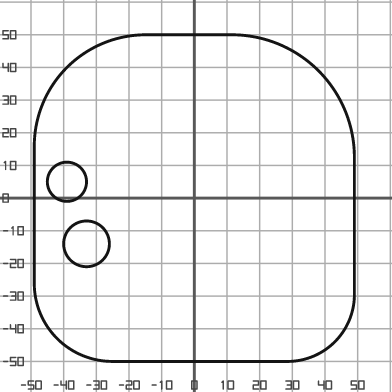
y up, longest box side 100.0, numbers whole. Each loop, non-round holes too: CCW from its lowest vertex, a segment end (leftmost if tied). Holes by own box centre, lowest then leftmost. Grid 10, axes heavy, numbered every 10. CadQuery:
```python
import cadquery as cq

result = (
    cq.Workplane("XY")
    .moveTo(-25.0, -50.0)
    .lineTo(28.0, -50.0)
    .threePointArc((43.0, -44.0), (49.0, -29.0))
    .lineTo(49.0, 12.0)
    .threePointArc((38.0, 39.0), (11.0, 50.0))
    .lineTo(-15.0, 50.0)
    .threePointArc((-39.0, 40.0), (-49.0, 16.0))
    .lineTo(-49.0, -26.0)
    .threePointArc((-42.0, -43.0), (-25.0, -50.0))
    .close()
    .moveTo(-33.0, -14.0)
    .circle(7.0)
    .moveTo(-39.0, 5.0)
    .circle(6.0)
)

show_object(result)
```